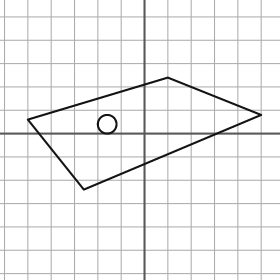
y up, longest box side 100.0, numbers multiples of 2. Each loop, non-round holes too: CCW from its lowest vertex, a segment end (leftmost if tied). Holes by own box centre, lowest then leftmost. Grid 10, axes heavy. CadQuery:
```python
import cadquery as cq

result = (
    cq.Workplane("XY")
    .moveTo(-26.0, -24.0)
    .lineTo(50.0, 8.0)
    .lineTo(10.0, 24.0)
    .lineTo(-50.0, 6.0)
    .close()
    .moveTo(-16.0, 4.0)
    .circle(4.0)
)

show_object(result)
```